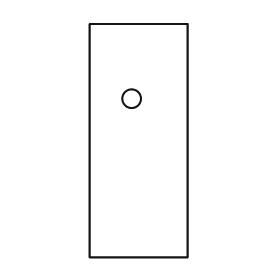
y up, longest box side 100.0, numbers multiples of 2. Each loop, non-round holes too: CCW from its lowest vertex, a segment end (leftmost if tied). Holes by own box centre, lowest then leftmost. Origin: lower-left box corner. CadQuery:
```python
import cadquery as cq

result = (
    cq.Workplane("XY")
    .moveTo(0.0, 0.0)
    .lineTo(42.0, 0.0)
    .lineTo(42.0, 100.0)
    .lineTo(0.0, 100.0)
    .close()
    .moveTo(18.0, 68.0)
    .circle(4.0)
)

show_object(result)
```